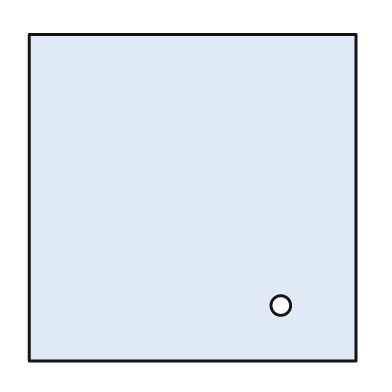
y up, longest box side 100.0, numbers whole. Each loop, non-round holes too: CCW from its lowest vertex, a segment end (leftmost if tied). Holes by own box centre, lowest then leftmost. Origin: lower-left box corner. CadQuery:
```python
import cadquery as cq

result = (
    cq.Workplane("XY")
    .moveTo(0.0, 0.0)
    .lineTo(100.0, 0.0)
    .lineTo(100.0, 100.0)
    .lineTo(0.0, 100.0)
    .close()
    .moveTo(77.0, 17.0)
    .circle(3.0)
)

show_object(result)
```